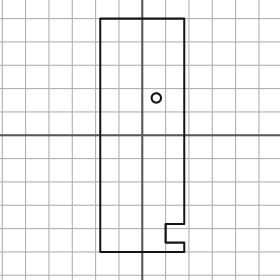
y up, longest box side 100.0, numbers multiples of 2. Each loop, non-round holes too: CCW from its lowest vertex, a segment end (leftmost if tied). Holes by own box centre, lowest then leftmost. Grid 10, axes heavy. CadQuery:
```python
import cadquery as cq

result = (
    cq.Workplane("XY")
    .moveTo(-18.0, -50.0)
    .lineTo(18.0, -50.0)
    .lineTo(18.0, -46.0)
    .lineTo(10.0, -46.0)
    .lineTo(10.0, -38.0)
    .lineTo(18.0, -38.0)
    .lineTo(18.0, 50.0)
    .lineTo(-18.0, 50.0)
    .close()
    .moveTo(6.0, 16.0)
    .circle(2.0)
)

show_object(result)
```